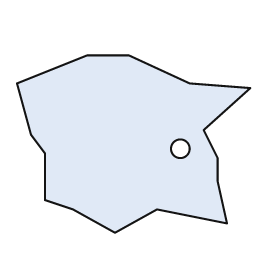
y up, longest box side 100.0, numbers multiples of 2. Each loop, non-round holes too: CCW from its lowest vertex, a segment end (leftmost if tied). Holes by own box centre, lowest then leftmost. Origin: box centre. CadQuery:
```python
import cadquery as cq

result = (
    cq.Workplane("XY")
    .moveTo(-8.0, -38.0)
    .lineTo(10.0, -28.0)
    .lineTo(40.0, -34.0)
    .lineTo(36.0, -16.0)
    .lineTo(36.0, -6.0)
    .lineTo(30.0, 6.0)
    .lineTo(50.0, 24.0)
    .lineTo(24.0, 26.0)
    .lineTo(-2.0, 38.0)
    .lineTo(-20.0, 38.0)
    .lineTo(-50.0, 26.0)
    .lineTo(-44.0, 4.0)
    .lineTo(-38.0, -4.0)
    .lineTo(-38.0, -24.0)
    .lineTo(-26.0, -28.0)
    .close()
    .moveTo(20.0, -2.0)
    .circle(4.0)
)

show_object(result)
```